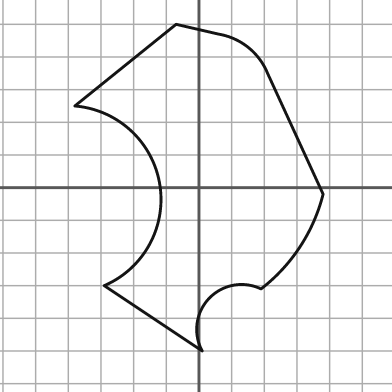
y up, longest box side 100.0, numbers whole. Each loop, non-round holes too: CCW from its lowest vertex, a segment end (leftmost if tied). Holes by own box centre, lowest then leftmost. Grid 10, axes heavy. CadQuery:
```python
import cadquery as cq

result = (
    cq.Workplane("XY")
    .moveTo(1.0, -50.0)
    .threePointArc((3.0, -34.0), (19.0, -31.0))
    .threePointArc((31.0, -18.0), (38.0, -2.0))
    .lineTo(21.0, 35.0)
    .threePointArc((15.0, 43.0), (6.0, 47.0))
    .lineTo(-7.0, 50.0)
    .lineTo(-38.0, 25.0)
    .threePointArc((-12.0, 1.0), (-29.0, -30.0))
    .close()
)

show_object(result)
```